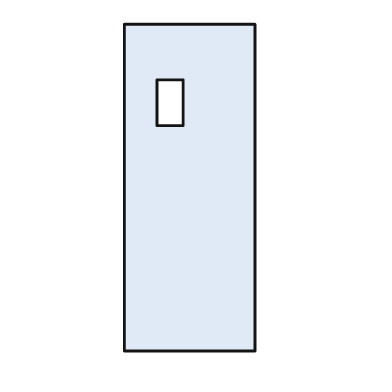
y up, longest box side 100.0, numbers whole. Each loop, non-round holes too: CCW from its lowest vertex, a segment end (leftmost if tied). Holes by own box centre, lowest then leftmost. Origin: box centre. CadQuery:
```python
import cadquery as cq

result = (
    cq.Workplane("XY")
    .moveTo(-20.0, -50.0)
    .lineTo(20.0, -50.0)
    .lineTo(20.0, 50.0)
    .lineTo(-20.0, 50.0)
    .close()
    .moveTo(-10.0, 19.0)
    .lineTo(-2.0, 19.0)
    .lineTo(-2.0, 33.0)
    .lineTo(-10.0, 33.0)
    .close()
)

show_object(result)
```